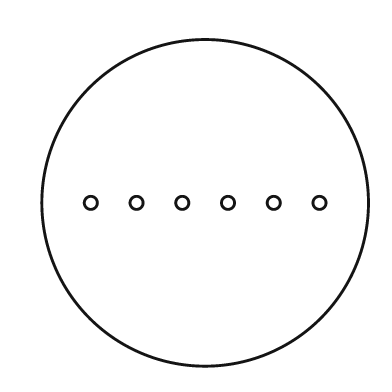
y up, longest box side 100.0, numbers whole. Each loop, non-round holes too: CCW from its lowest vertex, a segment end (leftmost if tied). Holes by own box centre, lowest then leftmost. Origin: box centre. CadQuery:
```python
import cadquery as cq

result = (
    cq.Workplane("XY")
    .moveTo(0.0, 0.0)
    .circle(50.0)
    .moveTo(-35.0, 0.0)
    .circle(2.0)
    .moveTo(-21.0, 0.0)
    .circle(2.0)
    .moveTo(-7.0, 0.0)
    .circle(2.0)
    .moveTo(7.0, 0.0)
    .circle(2.0)
    .moveTo(21.0, 0.0)
    .circle(2.0)
    .moveTo(35.0, 0.0)
    .circle(2.0)
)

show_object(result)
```